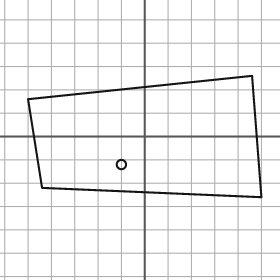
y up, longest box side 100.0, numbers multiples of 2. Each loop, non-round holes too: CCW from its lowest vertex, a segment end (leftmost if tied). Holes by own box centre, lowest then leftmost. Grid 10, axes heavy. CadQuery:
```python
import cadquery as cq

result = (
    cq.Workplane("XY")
    .moveTo(50.0, -26.0)
    .lineTo(46.0, 26.0)
    .lineTo(-50.0, 16.0)
    .lineTo(-44.0, -22.0)
    .close()
    .moveTo(-10.0, -12.0)
    .circle(2.0)
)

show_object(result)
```